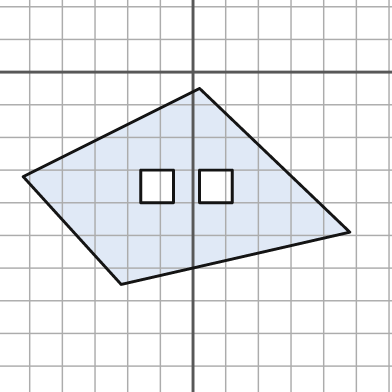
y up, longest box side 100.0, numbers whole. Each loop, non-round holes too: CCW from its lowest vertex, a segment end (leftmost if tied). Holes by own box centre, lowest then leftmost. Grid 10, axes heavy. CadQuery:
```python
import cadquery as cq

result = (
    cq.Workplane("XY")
    .moveTo(-22.0, -65.0)
    .lineTo(48.0, -49.0)
    .lineTo(2.0, -5.0)
    .lineTo(-52.0, -32.0)
    .close()
    .moveTo(-16.0, -40.0)
    .lineTo(-6.0, -40.0)
    .lineTo(-6.0, -30.0)
    .lineTo(-16.0, -30.0)
    .close()
    .moveTo(2.0, -40.0)
    .lineTo(12.0, -40.0)
    .lineTo(12.0, -30.0)
    .lineTo(2.0, -30.0)
    .close()
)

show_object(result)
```